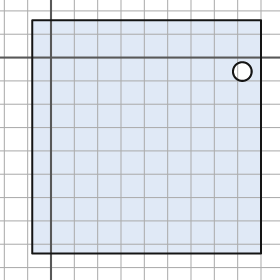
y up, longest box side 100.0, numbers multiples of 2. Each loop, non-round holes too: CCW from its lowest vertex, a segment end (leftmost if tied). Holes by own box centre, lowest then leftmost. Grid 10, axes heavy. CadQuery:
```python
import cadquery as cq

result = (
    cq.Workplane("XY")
    .moveTo(-8.0, -84.0)
    .lineTo(90.0, -84.0)
    .lineTo(90.0, 16.0)
    .lineTo(-8.0, 16.0)
    .close()
    .moveTo(82.0, -6.0)
    .circle(4.0)
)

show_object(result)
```